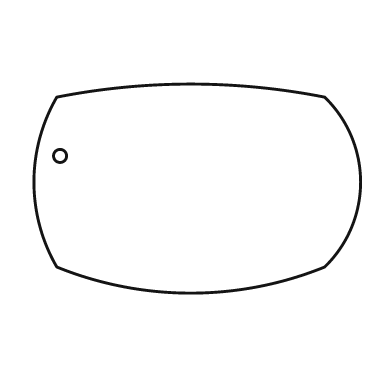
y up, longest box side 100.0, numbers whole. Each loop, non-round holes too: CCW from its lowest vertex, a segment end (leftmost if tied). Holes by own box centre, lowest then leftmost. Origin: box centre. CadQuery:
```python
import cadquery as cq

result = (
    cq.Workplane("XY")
    .moveTo(-43.0, -24.0)
    .threePointArc((-2.0, -32.0), (39.0, -24.0))
    .threePointArc((50.0, 2.0), (39.0, 28.0))
    .threePointArc((-2.0, 32.0), (-43.0, 28.0))
    .threePointArc((-50.0, 2.0), (-43.0, -24.0))
    .close()
    .moveTo(-42.0, 10.0)
    .circle(2.0)
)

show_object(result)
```